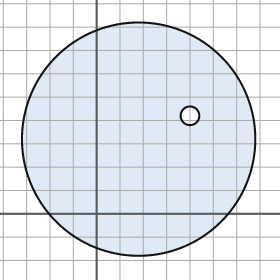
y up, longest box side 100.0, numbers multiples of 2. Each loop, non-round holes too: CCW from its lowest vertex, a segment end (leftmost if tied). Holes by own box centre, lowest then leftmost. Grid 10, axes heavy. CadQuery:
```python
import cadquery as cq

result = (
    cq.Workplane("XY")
    .moveTo(18.0, 32.0)
    .circle(50.0)
    .moveTo(40.0, 42.0)
    .circle(4.0)
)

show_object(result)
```